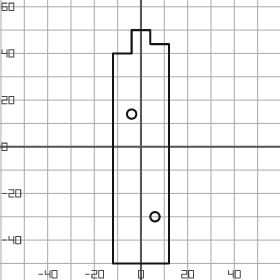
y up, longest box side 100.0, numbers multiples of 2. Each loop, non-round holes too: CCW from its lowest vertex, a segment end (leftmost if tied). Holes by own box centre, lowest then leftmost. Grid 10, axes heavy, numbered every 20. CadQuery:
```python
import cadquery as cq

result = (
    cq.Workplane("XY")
    .moveTo(-12.0, -50.0)
    .lineTo(12.0, -50.0)
    .lineTo(12.0, 44.0)
    .lineTo(4.0, 44.0)
    .lineTo(4.0, 50.0)
    .lineTo(-4.0, 50.0)
    .lineTo(-4.0, 40.0)
    .lineTo(-12.0, 40.0)
    .close()
    .moveTo(6.0, -30.0)
    .circle(2.0)
    .moveTo(-4.0, 14.0)
    .circle(2.0)
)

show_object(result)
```